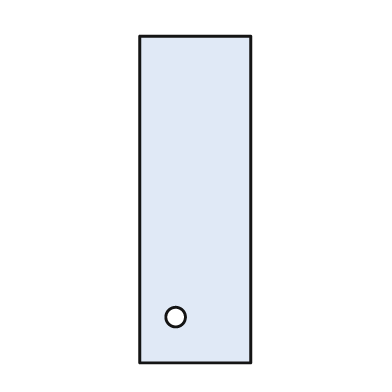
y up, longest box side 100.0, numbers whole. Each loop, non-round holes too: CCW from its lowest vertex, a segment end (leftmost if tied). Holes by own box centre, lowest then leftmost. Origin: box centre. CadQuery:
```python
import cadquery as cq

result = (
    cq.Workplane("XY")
    .moveTo(-17.0, -50.0)
    .lineTo(17.0, -50.0)
    .lineTo(17.0, 50.0)
    .lineTo(-17.0, 50.0)
    .close()
    .moveTo(-6.0, -36.0)
    .circle(3.0)
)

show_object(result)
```